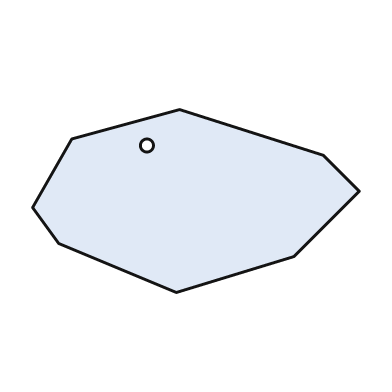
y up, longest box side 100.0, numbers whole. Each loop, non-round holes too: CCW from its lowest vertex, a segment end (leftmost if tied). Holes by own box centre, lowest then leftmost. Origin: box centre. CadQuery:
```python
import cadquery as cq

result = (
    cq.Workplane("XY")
    .moveTo(-6.0, -28.0)
    .lineTo(30.0, -17.0)
    .lineTo(50.0, 3.0)
    .lineTo(39.0, 14.0)
    .lineTo(-5.0, 28.0)
    .lineTo(-38.0, 19.0)
    .lineTo(-50.0, -2.0)
    .lineTo(-42.0, -13.0)
    .close()
    .moveTo(-15.0, 17.0)
    .circle(2.0)
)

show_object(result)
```